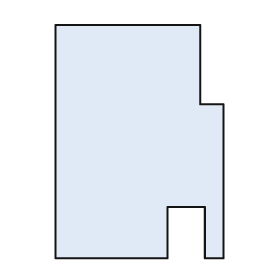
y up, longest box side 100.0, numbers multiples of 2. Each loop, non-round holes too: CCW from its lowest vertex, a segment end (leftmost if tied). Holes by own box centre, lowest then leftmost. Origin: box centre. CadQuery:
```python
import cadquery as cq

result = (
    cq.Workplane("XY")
    .moveTo(-36.0, -50.0)
    .lineTo(12.0, -50.0)
    .lineTo(12.0, -28.0)
    .lineTo(28.0, -28.0)
    .lineTo(28.0, -50.0)
    .lineTo(36.0, -50.0)
    .lineTo(36.0, 16.0)
    .lineTo(26.0, 16.0)
    .lineTo(26.0, 50.0)
    .lineTo(-36.0, 50.0)
    .close()
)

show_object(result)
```